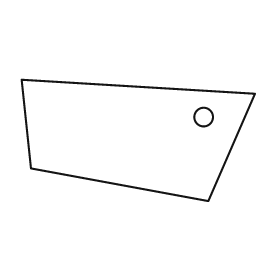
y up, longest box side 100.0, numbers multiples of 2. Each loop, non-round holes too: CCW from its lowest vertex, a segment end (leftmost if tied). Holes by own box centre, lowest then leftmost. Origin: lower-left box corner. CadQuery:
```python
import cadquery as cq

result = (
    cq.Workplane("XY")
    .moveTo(80.0, 0.0)
    .lineTo(100.0, 46.0)
    .lineTo(0.0, 52.0)
    .lineTo(4.0, 14.0)
    .close()
    .moveTo(78.0, 36.0)
    .circle(4.0)
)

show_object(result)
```